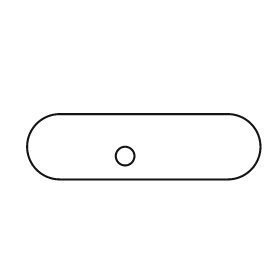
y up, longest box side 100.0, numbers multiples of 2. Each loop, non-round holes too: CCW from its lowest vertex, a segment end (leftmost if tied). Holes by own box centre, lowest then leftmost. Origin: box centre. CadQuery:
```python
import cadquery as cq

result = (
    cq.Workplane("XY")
    .moveTo(-36.0, -14.0)
    .lineTo(36.0, -14.0)
    .threePointArc((50.0, 0.0), (36.0, 14.0))
    .lineTo(-36.0, 14.0)
    .threePointArc((-50.0, 0.0), (-36.0, -14.0))
    .close()
    .moveTo(-8.0, -4.0)
    .circle(4.0)
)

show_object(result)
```